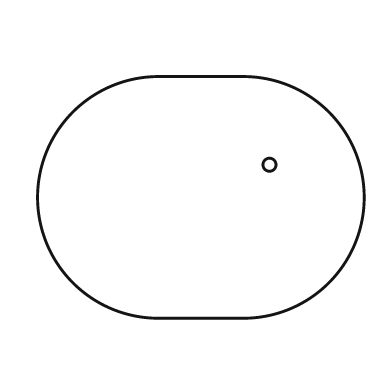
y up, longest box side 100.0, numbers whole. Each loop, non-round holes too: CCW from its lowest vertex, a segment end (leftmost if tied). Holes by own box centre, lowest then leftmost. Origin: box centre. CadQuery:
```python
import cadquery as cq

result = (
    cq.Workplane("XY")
    .moveTo(-13.0, -37.0)
    .lineTo(13.0, -37.0)
    .threePointArc((50.0, 0.0), (13.0, 37.0))
    .lineTo(-13.0, 37.0)
    .threePointArc((-50.0, 0.0), (-13.0, -37.0))
    .close()
    .moveTo(21.0, 10.0)
    .circle(2.0)
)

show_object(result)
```